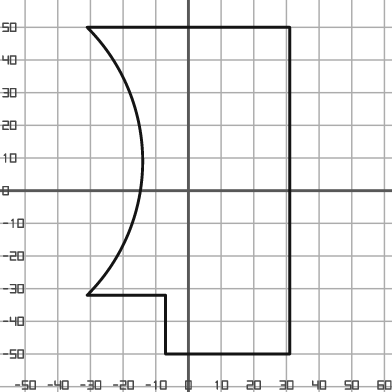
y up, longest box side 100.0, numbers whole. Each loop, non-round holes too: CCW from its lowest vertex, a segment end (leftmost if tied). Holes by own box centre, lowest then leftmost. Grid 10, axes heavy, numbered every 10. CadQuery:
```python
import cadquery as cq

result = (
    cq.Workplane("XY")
    .moveTo(-7.0, -50.0)
    .lineTo(31.0, -50.0)
    .lineTo(31.0, 50.0)
    .lineTo(-31.0, 50.0)
    .threePointArc((-14.0, 9.0), (-31.0, -32.0))
    .lineTo(-7.0, -32.0)
    .close()
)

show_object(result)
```